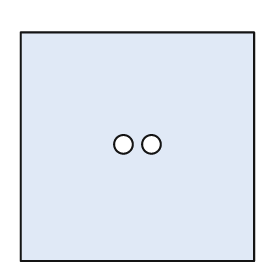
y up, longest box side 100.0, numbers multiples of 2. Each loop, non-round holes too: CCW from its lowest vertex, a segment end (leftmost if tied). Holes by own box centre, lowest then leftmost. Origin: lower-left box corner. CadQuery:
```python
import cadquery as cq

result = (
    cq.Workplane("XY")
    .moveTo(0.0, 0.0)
    .lineTo(100.0, 0.0)
    .lineTo(100.0, 98.0)
    .lineTo(0.0, 98.0)
    .close()
    .moveTo(44.0, 50.0)
    .circle(4.0)
    .moveTo(56.0, 50.0)
    .circle(4.0)
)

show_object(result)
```